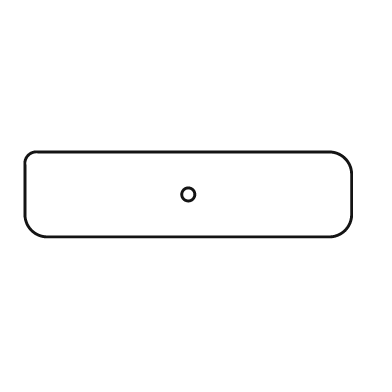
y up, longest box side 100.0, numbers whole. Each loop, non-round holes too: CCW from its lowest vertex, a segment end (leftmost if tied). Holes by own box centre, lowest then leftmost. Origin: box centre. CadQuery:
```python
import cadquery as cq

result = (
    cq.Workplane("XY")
    .moveTo(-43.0, -13.0)
    .lineTo(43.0, -13.0)
    .threePointArc((48.0, -11.0), (50.0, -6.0))
    .lineTo(50.0, 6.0)
    .threePointArc((48.0, 11.0), (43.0, 13.0))
    .lineTo(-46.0, 13.0)
    .threePointArc((-49.0, 12.0), (-50.0, 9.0))
    .lineTo(-50.0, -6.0)
    .threePointArc((-48.0, -11.0), (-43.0, -13.0))
    .close()
    .moveTo(0.0, 0.0)
    .circle(2.0)
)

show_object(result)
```